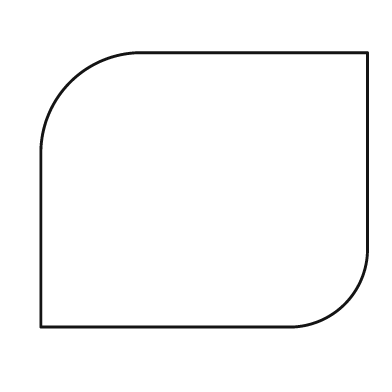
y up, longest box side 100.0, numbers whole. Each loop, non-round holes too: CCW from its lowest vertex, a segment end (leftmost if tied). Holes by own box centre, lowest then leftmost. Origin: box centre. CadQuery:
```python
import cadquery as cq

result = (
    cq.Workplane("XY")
    .moveTo(-50.0, -42.0)
    .lineTo(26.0, -42.0)
    .threePointArc((43.0, -35.0), (50.0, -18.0))
    .lineTo(50.0, 42.0)
    .lineTo(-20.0, 42.0)
    .threePointArc((-41.0, 33.0), (-50.0, 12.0))
    .close()
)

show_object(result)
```